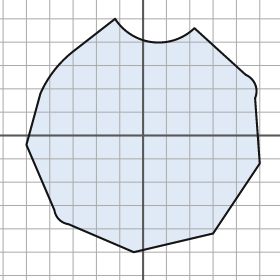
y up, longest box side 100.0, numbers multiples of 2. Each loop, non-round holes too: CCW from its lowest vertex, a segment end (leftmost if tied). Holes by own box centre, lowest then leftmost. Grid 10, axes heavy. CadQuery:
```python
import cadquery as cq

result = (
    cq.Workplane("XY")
    .moveTo(-4.0, -50.0)
    .lineTo(30.0, -42.0)
    .lineTo(50.0, -12.0)
    .lineTo(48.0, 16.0)
    .threePointArc((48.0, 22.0), (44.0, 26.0))
    .lineTo(22.0, 46.0)
    .threePointArc((4.0, 40.0), (-12.0, 50.0))
    .lineTo(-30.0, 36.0)
    .threePointArc((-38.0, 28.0), (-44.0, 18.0))
    .lineTo(-50.0, -4.0)
    .lineTo(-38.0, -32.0)
    .threePointArc((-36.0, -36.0), (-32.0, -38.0))
    .close()
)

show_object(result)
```